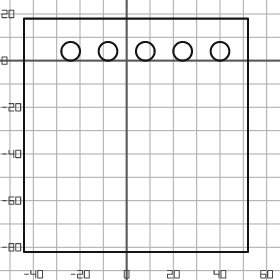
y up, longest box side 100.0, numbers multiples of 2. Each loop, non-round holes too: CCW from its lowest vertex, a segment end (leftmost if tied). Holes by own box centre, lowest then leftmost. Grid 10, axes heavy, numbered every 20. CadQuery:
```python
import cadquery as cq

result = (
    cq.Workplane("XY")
    .moveTo(-44.0, -82.0)
    .lineTo(52.0, -82.0)
    .lineTo(52.0, 18.0)
    .lineTo(-44.0, 18.0)
    .close()
    .moveTo(-24.0, 4.0)
    .circle(4.0)
    .moveTo(-8.0, 4.0)
    .circle(4.0)
    .moveTo(8.0, 4.0)
    .circle(4.0)
    .moveTo(24.0, 4.0)
    .circle(4.0)
    .moveTo(40.0, 4.0)
    .circle(4.0)
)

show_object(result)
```